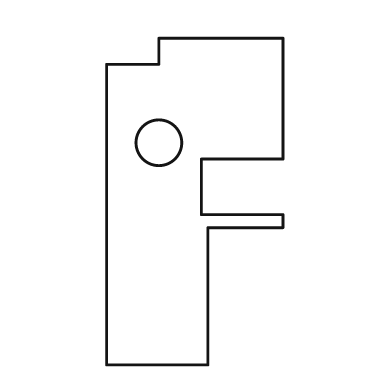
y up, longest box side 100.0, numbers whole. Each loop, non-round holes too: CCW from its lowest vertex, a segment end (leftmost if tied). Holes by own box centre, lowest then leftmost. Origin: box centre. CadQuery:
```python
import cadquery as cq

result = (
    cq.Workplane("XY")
    .moveTo(-27.0, -50.0)
    .lineTo(4.0, -50.0)
    .lineTo(4.0, -8.0)
    .lineTo(27.0, -8.0)
    .lineTo(27.0, -4.0)
    .lineTo(2.0, -4.0)
    .lineTo(2.0, 13.0)
    .lineTo(27.0, 13.0)
    .lineTo(27.0, 50.0)
    .lineTo(-11.0, 50.0)
    .lineTo(-11.0, 42.0)
    .lineTo(-27.0, 42.0)
    .close()
    .moveTo(-11.0, 18.0)
    .circle(7.0)
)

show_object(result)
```